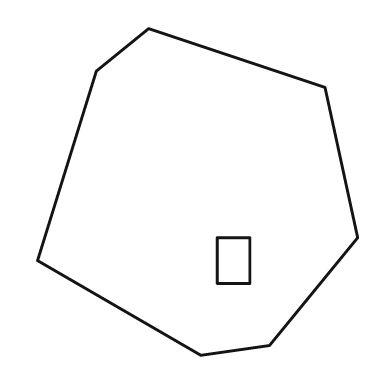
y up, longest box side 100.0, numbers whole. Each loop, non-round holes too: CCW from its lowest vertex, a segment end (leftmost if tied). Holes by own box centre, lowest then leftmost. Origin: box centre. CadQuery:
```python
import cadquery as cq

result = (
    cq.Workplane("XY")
    .moveTo(1.0, -50.0)
    .lineTo(22.0, -47.0)
    .lineTo(49.0, -14.0)
    .lineTo(39.0, 32.0)
    .lineTo(-15.0, 50.0)
    .lineTo(-31.0, 37.0)
    .lineTo(-49.0, -21.0)
    .close()
    .moveTo(6.0, -28.0)
    .lineTo(16.0, -28.0)
    .lineTo(16.0, -14.0)
    .lineTo(6.0, -14.0)
    .close()
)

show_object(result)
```